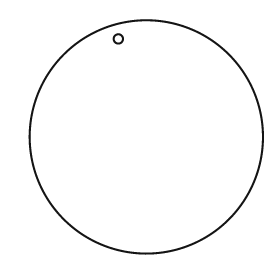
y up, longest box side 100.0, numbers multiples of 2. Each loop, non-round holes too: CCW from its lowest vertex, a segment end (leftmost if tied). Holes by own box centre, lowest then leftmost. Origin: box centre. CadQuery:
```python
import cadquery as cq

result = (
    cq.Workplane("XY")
    .moveTo(0.0, 0.0)
    .circle(50.0)
    .moveTo(-12.0, 42.0)
    .circle(2.0)
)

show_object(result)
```